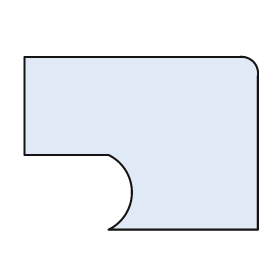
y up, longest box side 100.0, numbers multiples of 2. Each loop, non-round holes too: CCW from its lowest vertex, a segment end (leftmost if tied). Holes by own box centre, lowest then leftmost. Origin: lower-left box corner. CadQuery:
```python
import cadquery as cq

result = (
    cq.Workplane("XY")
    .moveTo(36.0, 0.0)
    .lineTo(100.0, 0.0)
    .lineTo(100.0, 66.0)
    .threePointArc((98.0, 72.0), (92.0, 74.0))
    .lineTo(0.0, 74.0)
    .lineTo(0.0, 32.0)
    .lineTo(36.0, 32.0)
    .threePointArc((46.0, 16.0), (36.0, 0.0))
    .close()
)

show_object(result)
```